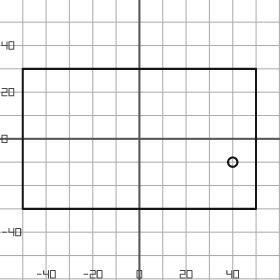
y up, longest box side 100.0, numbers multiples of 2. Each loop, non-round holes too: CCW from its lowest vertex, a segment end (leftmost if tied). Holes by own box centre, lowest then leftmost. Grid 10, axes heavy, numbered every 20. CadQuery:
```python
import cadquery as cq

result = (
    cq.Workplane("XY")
    .moveTo(-50.0, -30.0)
    .lineTo(50.0, -30.0)
    .lineTo(50.0, 30.0)
    .lineTo(-50.0, 30.0)
    .close()
    .moveTo(40.0, -10.0)
    .circle(2.0)
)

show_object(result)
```